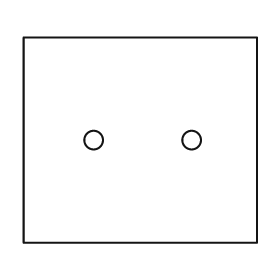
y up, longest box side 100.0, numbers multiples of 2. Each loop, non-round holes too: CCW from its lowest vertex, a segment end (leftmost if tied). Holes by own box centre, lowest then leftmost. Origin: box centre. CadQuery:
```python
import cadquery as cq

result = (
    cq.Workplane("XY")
    .moveTo(-50.0, -44.0)
    .lineTo(50.0, -44.0)
    .lineTo(50.0, 44.0)
    .lineTo(-50.0, 44.0)
    .close()
    .moveTo(-20.0, 0.0)
    .circle(4.0)
    .moveTo(22.0, 0.0)
    .circle(4.0)
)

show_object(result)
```